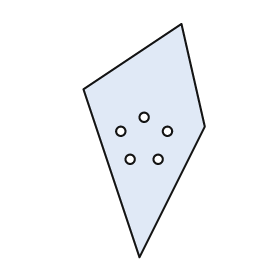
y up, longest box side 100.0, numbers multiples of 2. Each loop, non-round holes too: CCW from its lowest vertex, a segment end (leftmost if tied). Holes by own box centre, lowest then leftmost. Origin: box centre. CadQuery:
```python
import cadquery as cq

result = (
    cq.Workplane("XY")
    .moveTo(-2.0, -50.0)
    .lineTo(26.0, 6.0)
    .lineTo(16.0, 50.0)
    .lineTo(-26.0, 22.0)
    .close()
    .moveTo(-6.0, -8.0)
    .circle(2.0)
    .moveTo(6.0, -8.0)
    .circle(2.0)
    .moveTo(-10.0, 4.0)
    .circle(2.0)
    .moveTo(10.0, 4.0)
    .circle(2.0)
    .moveTo(0.0, 10.0)
    .circle(2.0)
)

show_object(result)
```